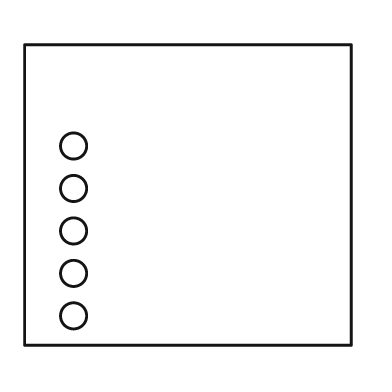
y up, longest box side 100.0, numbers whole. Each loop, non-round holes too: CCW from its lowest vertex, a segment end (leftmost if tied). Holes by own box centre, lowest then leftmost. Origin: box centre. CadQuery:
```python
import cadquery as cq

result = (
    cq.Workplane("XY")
    .moveTo(-50.0, -46.0)
    .lineTo(50.0, -46.0)
    .lineTo(50.0, 46.0)
    .lineTo(-50.0, 46.0)
    .close()
    .moveTo(-35.0, -37.0)
    .circle(4.0)
    .moveTo(-35.0, -24.0)
    .circle(4.0)
    .moveTo(-35.0, -11.0)
    .circle(4.0)
    .moveTo(-35.0, 2.0)
    .circle(4.0)
    .moveTo(-35.0, 15.0)
    .circle(4.0)
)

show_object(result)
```